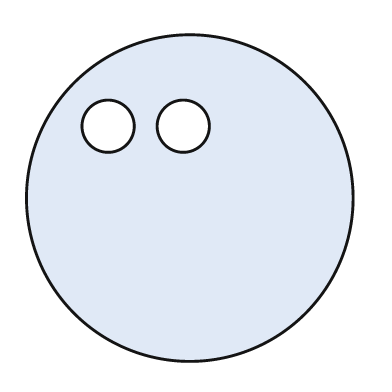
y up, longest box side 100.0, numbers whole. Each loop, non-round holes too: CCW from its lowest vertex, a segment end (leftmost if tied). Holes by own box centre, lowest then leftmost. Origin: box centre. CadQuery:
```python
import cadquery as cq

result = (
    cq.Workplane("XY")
    .moveTo(0.0, 0.0)
    .circle(50.0)
    .moveTo(-25.0, 22.0)
    .circle(8.0)
    .moveTo(-2.0, 22.0)
    .circle(8.0)
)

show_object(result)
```